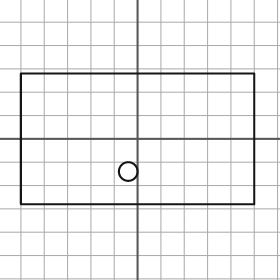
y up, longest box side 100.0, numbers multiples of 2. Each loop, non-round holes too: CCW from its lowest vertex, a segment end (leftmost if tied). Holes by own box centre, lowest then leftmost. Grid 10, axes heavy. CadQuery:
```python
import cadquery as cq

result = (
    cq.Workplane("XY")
    .moveTo(-50.0, -28.0)
    .lineTo(50.0, -28.0)
    .lineTo(50.0, 28.0)
    .lineTo(-50.0, 28.0)
    .close()
    .moveTo(-4.0, -14.0)
    .circle(4.0)
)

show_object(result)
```